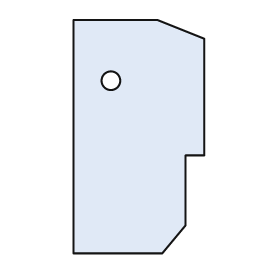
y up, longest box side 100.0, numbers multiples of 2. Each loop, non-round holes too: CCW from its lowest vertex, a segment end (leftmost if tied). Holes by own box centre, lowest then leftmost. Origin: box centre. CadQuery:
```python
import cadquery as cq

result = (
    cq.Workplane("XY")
    .moveTo(-28.0, -50.0)
    .lineTo(10.0, -50.0)
    .lineTo(20.0, -38.0)
    .lineTo(20.0, -8.0)
    .lineTo(28.0, -8.0)
    .lineTo(28.0, 42.0)
    .lineTo(8.0, 50.0)
    .lineTo(-28.0, 50.0)
    .close()
    .moveTo(-12.0, 24.0)
    .circle(4.0)
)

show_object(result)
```